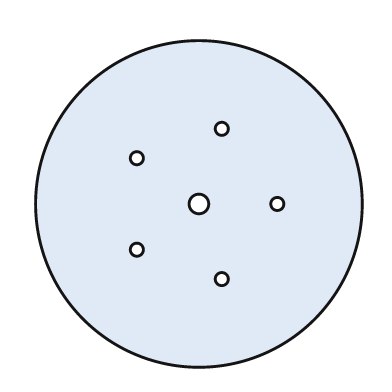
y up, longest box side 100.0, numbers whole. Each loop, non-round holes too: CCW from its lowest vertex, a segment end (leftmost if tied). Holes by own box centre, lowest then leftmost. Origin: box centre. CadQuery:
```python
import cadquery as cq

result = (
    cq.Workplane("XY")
    .moveTo(0.0, 0.0)
    .circle(50.0)
    .moveTo(7.0, -23.0)
    .circle(2.0)
    .moveTo(-19.0, -14.0)
    .circle(2.0)
    .moveTo(0.0, 0.0)
    .circle(3.0)
    .moveTo(24.0, 0.0)
    .circle(2.0)
    .moveTo(-19.0, 14.0)
    .circle(2.0)
    .moveTo(7.0, 23.0)
    .circle(2.0)
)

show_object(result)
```